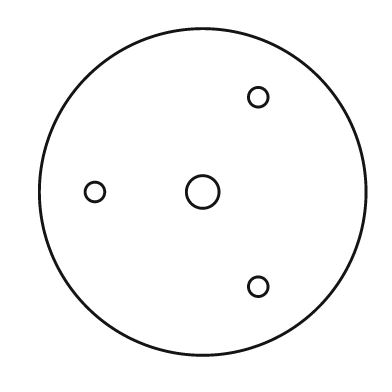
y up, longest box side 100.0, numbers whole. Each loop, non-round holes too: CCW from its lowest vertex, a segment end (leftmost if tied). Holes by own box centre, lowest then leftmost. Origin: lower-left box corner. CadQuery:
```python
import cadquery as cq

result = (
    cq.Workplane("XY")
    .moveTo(50.0, 50.0)
    .circle(50.0)
    .moveTo(67.0, 21.0)
    .circle(3.0)
    .moveTo(17.0, 50.0)
    .circle(3.0)
    .moveTo(50.0, 50.0)
    .circle(5.0)
    .moveTo(67.0, 79.0)
    .circle(3.0)
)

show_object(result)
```